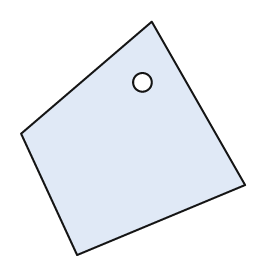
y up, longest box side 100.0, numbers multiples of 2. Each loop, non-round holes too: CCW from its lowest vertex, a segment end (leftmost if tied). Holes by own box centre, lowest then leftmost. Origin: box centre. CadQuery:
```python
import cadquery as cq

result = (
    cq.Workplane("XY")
    .moveTo(-24.0, -50.0)
    .lineTo(48.0, -20.0)
    .lineTo(8.0, 50.0)
    .lineTo(-48.0, 2.0)
    .close()
    .moveTo(4.0, 24.0)
    .circle(4.0)
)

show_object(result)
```